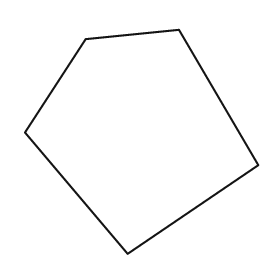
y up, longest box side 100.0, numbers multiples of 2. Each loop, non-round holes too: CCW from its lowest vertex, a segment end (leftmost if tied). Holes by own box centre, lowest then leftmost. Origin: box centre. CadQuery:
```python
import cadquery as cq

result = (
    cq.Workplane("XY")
    .moveTo(-6.0, -48.0)
    .lineTo(50.0, -10.0)
    .lineTo(16.0, 48.0)
    .lineTo(-24.0, 44.0)
    .lineTo(-50.0, 4.0)
    .close()
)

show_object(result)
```